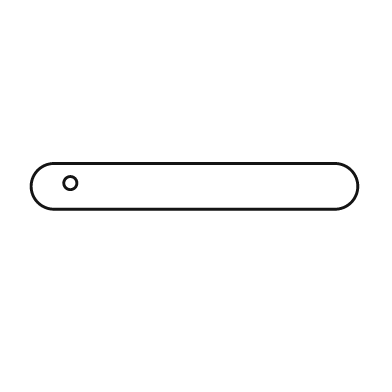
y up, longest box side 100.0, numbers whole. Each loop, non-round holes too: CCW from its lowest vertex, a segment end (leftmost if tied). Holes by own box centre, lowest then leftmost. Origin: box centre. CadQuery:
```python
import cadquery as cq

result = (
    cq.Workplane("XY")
    .moveTo(-43.0, -7.0)
    .lineTo(43.0, -7.0)
    .threePointArc((50.0, 0.0), (43.0, 7.0))
    .lineTo(-43.0, 7.0)
    .threePointArc((-50.0, 0.0), (-43.0, -7.0))
    .close()
    .moveTo(-38.0, 1.0)
    .circle(2.0)
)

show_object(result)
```